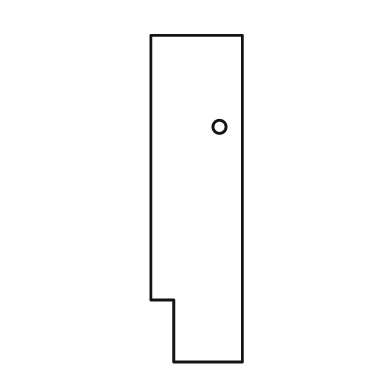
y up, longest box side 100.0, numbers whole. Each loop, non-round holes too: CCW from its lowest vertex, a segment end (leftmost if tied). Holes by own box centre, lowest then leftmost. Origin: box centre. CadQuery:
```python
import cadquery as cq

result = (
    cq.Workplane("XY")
    .moveTo(-7.0, -50.0)
    .lineTo(14.0, -50.0)
    .lineTo(14.0, 50.0)
    .lineTo(-14.0, 50.0)
    .lineTo(-14.0, -31.0)
    .lineTo(-7.0, -31.0)
    .close()
    .moveTo(7.0, 22.0)
    .circle(2.0)
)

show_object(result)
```